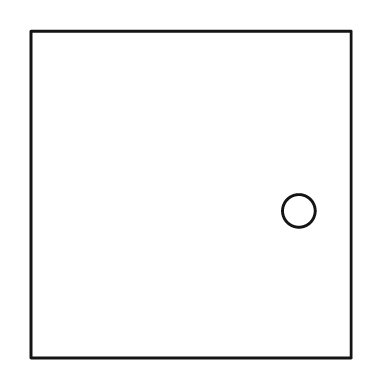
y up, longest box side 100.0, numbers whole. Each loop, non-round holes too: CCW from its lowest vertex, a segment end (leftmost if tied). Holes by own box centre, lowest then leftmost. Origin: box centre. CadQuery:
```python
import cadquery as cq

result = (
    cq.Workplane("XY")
    .moveTo(-49.0, -50.0)
    .lineTo(49.0, -50.0)
    .lineTo(49.0, 50.0)
    .lineTo(-49.0, 50.0)
    .close()
    .moveTo(33.0, -5.0)
    .circle(5.0)
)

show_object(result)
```